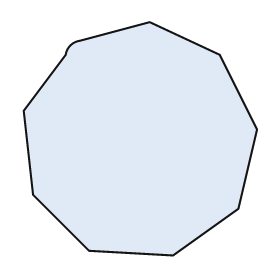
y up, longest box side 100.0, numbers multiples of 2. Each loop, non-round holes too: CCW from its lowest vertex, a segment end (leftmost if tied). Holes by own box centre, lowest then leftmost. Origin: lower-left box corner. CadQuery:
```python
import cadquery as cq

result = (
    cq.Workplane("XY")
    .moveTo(64.0, 0.0)
    .lineTo(92.0, 20.0)
    .lineTo(100.0, 54.0)
    .lineTo(84.0, 86.0)
    .lineTo(54.0, 100.0)
    .lineTo(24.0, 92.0)
    .threePointArc((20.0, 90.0), (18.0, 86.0))
    .lineTo(0.0, 62.0)
    .lineTo(4.0, 26.0)
    .lineTo(28.0, 2.0)
    .close()
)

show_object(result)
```